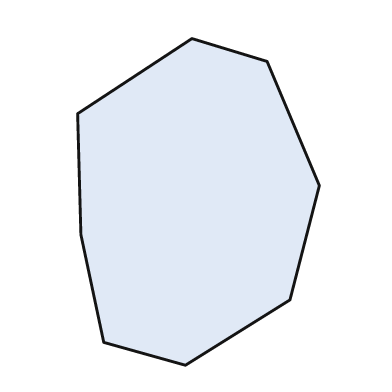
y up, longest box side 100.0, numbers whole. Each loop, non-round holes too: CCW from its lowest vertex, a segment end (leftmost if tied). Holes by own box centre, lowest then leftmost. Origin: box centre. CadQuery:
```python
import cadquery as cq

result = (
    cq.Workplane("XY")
    .moveTo(-4.0, -50.0)
    .lineTo(28.0, -30.0)
    .lineTo(37.0, 5.0)
    .lineTo(21.0, 43.0)
    .lineTo(-2.0, 50.0)
    .lineTo(-37.0, 27.0)
    .lineTo(-36.0, -10.0)
    .lineTo(-29.0, -43.0)
    .close()
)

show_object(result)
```